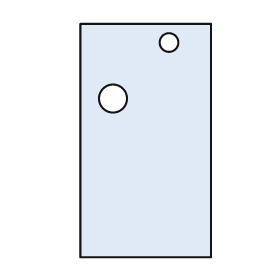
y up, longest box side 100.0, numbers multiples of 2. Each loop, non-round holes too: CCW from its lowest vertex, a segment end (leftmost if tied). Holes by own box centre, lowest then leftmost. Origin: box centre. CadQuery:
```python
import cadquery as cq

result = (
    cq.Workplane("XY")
    .moveTo(-28.0, -50.0)
    .lineTo(28.0, -50.0)
    .lineTo(28.0, 50.0)
    .lineTo(-28.0, 50.0)
    .close()
    .moveTo(-14.0, 18.0)
    .circle(6.0)
    .moveTo(10.0, 42.0)
    .circle(4.0)
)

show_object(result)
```